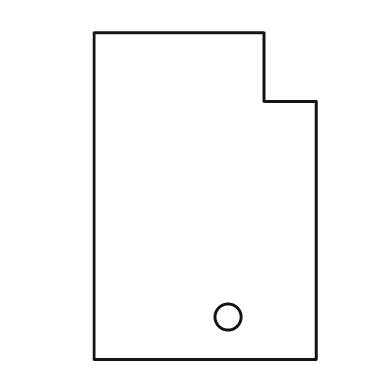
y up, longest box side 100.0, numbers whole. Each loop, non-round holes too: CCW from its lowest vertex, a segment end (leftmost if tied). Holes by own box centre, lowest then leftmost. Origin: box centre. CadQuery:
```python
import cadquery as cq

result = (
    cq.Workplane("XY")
    .moveTo(-34.0, -50.0)
    .lineTo(34.0, -50.0)
    .lineTo(34.0, 29.0)
    .lineTo(18.0, 29.0)
    .lineTo(18.0, 50.0)
    .lineTo(-34.0, 50.0)
    .close()
    .moveTo(7.0, -37.0)
    .circle(4.0)
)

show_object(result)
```